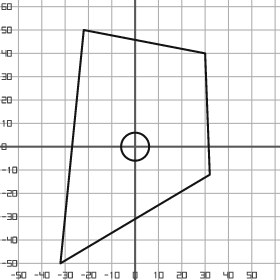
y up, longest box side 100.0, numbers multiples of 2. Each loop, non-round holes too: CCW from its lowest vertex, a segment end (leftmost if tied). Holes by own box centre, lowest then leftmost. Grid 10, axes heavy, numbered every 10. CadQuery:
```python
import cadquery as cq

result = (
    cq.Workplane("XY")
    .moveTo(-32.0, -50.0)
    .lineTo(32.0, -12.0)
    .lineTo(30.0, 40.0)
    .lineTo(-22.0, 50.0)
    .close()
    .moveTo(0.0, 0.0)
    .circle(6.0)
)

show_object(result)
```